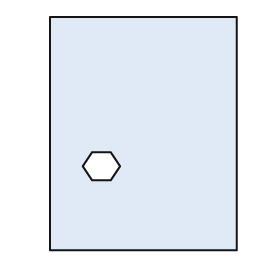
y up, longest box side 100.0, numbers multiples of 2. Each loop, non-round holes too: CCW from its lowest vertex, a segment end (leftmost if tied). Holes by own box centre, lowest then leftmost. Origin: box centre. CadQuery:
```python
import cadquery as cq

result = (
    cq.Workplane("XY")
    .moveTo(-40.0, -50.0)
    .lineTo(40.0, -50.0)
    .lineTo(40.0, 50.0)
    .lineTo(-40.0, 50.0)
    .close()
    .moveTo(-22.0, -20.0)
    .lineTo(-14.0, -20.0)
    .lineTo(-10.0, -14.0)
    .lineTo(-14.0, -8.0)
    .lineTo(-22.0, -8.0)
    .lineTo(-26.0, -14.0)
    .close()
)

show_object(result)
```